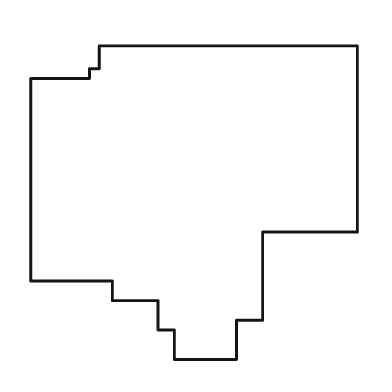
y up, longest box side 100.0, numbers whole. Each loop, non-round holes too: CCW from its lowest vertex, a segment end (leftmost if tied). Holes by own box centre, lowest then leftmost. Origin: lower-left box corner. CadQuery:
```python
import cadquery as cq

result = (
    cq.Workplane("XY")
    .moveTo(44.0, 0.0)
    .lineTo(63.0, 0.0)
    .lineTo(63.0, 12.0)
    .lineTo(71.0, 12.0)
    .lineTo(71.0, 39.0)
    .lineTo(100.0, 39.0)
    .lineTo(100.0, 96.0)
    .lineTo(21.0, 96.0)
    .lineTo(21.0, 89.0)
    .lineTo(18.0, 89.0)
    .lineTo(18.0, 86.0)
    .lineTo(0.0, 86.0)
    .lineTo(0.0, 24.0)
    .lineTo(25.0, 24.0)
    .lineTo(25.0, 18.0)
    .lineTo(39.0, 18.0)
    .lineTo(39.0, 9.0)
    .lineTo(44.0, 9.0)
    .close()
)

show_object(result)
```